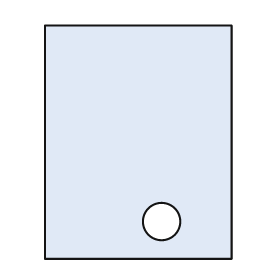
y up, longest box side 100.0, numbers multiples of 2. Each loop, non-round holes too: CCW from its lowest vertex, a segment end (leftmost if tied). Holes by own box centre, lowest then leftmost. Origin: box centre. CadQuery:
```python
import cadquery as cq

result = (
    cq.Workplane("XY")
    .moveTo(-40.0, -50.0)
    .lineTo(40.0, -50.0)
    .lineTo(40.0, 50.0)
    .lineTo(-40.0, 50.0)
    .close()
    .moveTo(10.0, -34.0)
    .circle(8.0)
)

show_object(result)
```